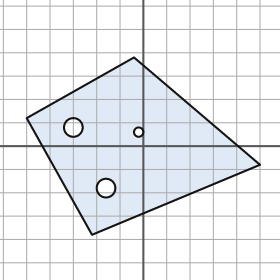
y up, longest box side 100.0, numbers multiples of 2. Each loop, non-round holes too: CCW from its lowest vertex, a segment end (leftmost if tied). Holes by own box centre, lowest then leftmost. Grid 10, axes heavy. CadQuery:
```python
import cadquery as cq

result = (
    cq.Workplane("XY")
    .moveTo(-22.0, -38.0)
    .lineTo(50.0, -8.0)
    .lineTo(-4.0, 38.0)
    .lineTo(-50.0, 12.0)
    .close()
    .moveTo(-16.0, -18.0)
    .circle(4.0)
    .moveTo(-2.0, 6.0)
    .circle(2.0)
    .moveTo(-30.0, 8.0)
    .circle(4.0)
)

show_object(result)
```